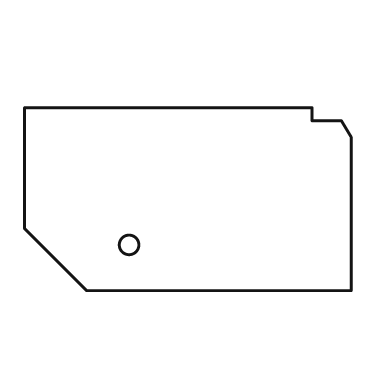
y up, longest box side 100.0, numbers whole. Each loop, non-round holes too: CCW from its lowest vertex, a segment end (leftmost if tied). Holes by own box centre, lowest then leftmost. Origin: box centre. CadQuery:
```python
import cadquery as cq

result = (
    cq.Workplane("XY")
    .moveTo(-31.0, -28.0)
    .lineTo(50.0, -28.0)
    .lineTo(50.0, 19.0)
    .lineTo(47.0, 24.0)
    .lineTo(38.0, 24.0)
    .lineTo(38.0, 28.0)
    .lineTo(-50.0, 28.0)
    .lineTo(-50.0, -9.0)
    .close()
    .moveTo(-18.0, -14.0)
    .circle(3.0)
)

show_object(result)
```